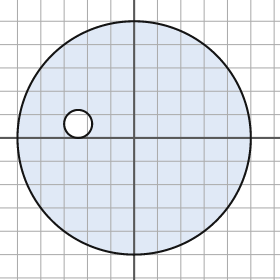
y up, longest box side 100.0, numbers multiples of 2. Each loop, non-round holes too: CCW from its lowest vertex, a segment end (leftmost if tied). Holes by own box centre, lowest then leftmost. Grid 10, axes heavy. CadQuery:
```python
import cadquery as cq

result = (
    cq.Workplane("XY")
    .moveTo(0.0, 0.0)
    .circle(50.0)
    .moveTo(-24.0, 6.0)
    .circle(6.0)
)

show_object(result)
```